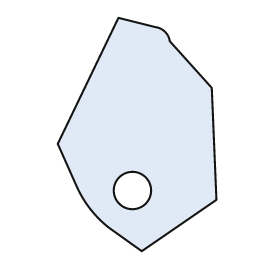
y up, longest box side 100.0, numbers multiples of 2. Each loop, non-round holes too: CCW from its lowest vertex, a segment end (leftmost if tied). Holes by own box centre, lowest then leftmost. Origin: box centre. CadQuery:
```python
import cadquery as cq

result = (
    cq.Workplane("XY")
    .moveTo(2.0, -50.0)
    .lineTo(34.0, -28.0)
    .lineTo(32.0, 20.0)
    .lineTo(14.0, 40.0)
    .threePointArc((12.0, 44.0), (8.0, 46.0))
    .lineTo(-8.0, 50.0)
    .lineTo(-34.0, -4.0)
    .lineTo(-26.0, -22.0)
    .threePointArc((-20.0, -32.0), (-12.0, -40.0))
    .close()
    .moveTo(-2.0, -24.0)
    .circle(8.0)
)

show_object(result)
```